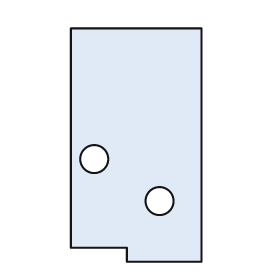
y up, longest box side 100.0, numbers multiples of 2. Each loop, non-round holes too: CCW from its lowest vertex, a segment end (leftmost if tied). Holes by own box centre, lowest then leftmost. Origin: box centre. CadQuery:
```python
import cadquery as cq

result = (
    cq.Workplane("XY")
    .moveTo(-4.0, -50.0)
    .lineTo(28.0, -50.0)
    .lineTo(28.0, 50.0)
    .lineTo(-28.0, 50.0)
    .lineTo(-28.0, -44.0)
    .lineTo(-4.0, -44.0)
    .close()
    .moveTo(10.0, -24.0)
    .circle(6.0)
    .moveTo(-18.0, -6.0)
    .circle(6.0)
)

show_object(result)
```